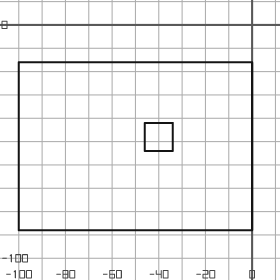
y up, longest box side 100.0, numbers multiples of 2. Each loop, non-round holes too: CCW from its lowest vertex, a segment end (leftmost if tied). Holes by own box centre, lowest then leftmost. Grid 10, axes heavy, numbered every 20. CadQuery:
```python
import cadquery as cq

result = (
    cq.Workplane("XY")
    .moveTo(-100.0, -88.0)
    .lineTo(0.0, -88.0)
    .lineTo(0.0, -16.0)
    .lineTo(-100.0, -16.0)
    .close()
    .moveTo(-46.0, -54.0)
    .lineTo(-34.0, -54.0)
    .lineTo(-34.0, -42.0)
    .lineTo(-46.0, -42.0)
    .close()
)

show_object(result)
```